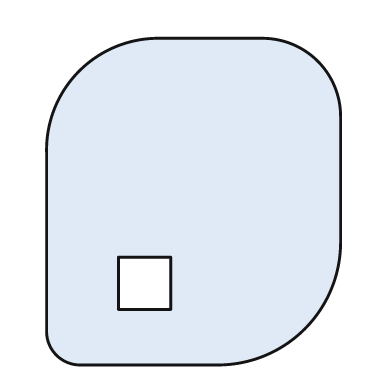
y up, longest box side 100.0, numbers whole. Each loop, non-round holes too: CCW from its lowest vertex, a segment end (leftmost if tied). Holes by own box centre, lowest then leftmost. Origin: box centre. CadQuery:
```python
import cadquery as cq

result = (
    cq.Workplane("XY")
    .moveTo(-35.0, -50.0)
    .lineTo(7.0, -50.0)
    .threePointArc((34.0, -39.0), (45.0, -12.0))
    .lineTo(45.0, 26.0)
    .threePointArc((38.0, 43.0), (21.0, 50.0))
    .lineTo(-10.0, 50.0)
    .threePointArc((-35.0, 40.0), (-45.0, 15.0))
    .lineTo(-45.0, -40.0)
    .threePointArc((-42.0, -47.0), (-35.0, -50.0))
    .close()
    .moveTo(-23.0, -33.0)
    .lineTo(-7.0, -33.0)
    .lineTo(-7.0, -17.0)
    .lineTo(-23.0, -17.0)
    .close()
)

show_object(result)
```